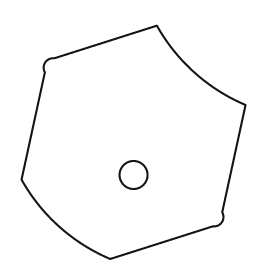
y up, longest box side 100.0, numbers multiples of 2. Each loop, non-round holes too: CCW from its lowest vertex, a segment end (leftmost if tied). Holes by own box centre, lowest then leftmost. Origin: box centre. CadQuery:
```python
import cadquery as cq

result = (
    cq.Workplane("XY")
    .moveTo(-10.0, -50.0)
    .lineTo(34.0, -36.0)
    .threePointArc((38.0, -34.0), (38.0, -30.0))
    .lineTo(48.0, 16.0)
    .threePointArc((26.0, 30.0), (10.0, 50.0))
    .lineTo(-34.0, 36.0)
    .threePointArc((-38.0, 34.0), (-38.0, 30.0))
    .lineTo(-48.0, -16.0)
    .threePointArc((-32.0, -36.0), (-10.0, -50.0))
    .close()
    .moveTo(0.0, -14.0)
    .circle(6.0)
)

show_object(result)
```